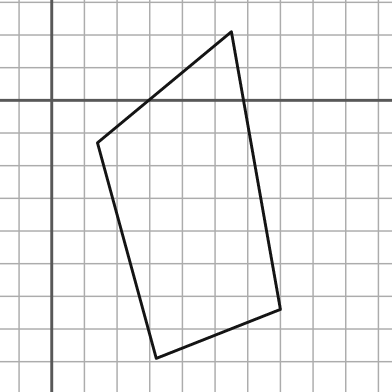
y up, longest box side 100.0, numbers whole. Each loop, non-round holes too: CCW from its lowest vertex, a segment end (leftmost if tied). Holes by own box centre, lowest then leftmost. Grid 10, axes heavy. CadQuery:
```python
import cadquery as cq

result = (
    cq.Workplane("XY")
    .moveTo(32.0, -79.0)
    .lineTo(70.0, -64.0)
    .lineTo(55.0, 21.0)
    .lineTo(14.0, -13.0)
    .close()
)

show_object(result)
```